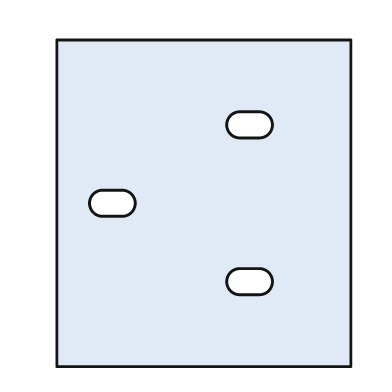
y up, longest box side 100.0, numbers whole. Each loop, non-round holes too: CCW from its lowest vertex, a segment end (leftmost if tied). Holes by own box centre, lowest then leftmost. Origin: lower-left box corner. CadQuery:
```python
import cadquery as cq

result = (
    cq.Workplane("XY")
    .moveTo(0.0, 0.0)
    .lineTo(90.0, 0.0)
    .lineTo(90.0, 100.0)
    .lineTo(0.0, 100.0)
    .close()
    .moveTo(56.0, 22.0)
    .lineTo(62.0, 22.0)
    .threePointArc((66.0, 26.0), (62.0, 30.0))
    .lineTo(56.0, 30.0)
    .threePointArc((52.0, 26.0), (56.0, 22.0))
    .close()
    .moveTo(14.0, 46.0)
    .lineTo(20.0, 46.0)
    .threePointArc((24.0, 50.0), (20.0, 54.0))
    .lineTo(14.0, 54.0)
    .threePointArc((10.0, 50.0), (14.0, 46.0))
    .close()
    .moveTo(56.0, 70.0)
    .lineTo(62.0, 70.0)
    .threePointArc((66.0, 74.0), (62.0, 78.0))
    .lineTo(56.0, 78.0)
    .threePointArc((52.0, 74.0), (56.0, 70.0))
    .close()
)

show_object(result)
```